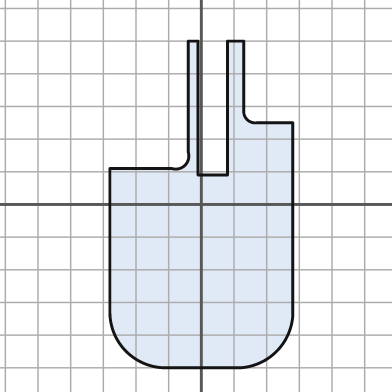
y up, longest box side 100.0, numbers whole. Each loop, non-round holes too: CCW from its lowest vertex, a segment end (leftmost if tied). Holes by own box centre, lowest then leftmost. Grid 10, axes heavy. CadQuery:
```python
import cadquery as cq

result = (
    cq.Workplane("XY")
    .moveTo(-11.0, -50.0)
    .lineTo(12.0, -50.0)
    .threePointArc((23.0, -45.0), (28.0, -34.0))
    .lineTo(28.0, 25.0)
    .lineTo(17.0, 25.0)
    .threePointArc((14.0, 26.0), (13.0, 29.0))
    .lineTo(13.0, 50.0)
    .lineTo(8.0, 50.0)
    .lineTo(8.0, 9.0)
    .lineTo(-1.0, 9.0)
    .lineTo(-1.0, 50.0)
    .lineTo(-4.0, 50.0)
    .lineTo(-4.0, 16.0)
    .threePointArc((-5.0, 12.0), (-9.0, 11.0))
    .lineTo(-28.0, 11.0)
    .lineTo(-28.0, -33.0)
    .threePointArc((-23.0, -45.0), (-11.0, -50.0))
    .close()
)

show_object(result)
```